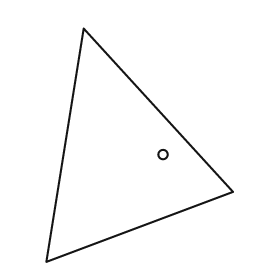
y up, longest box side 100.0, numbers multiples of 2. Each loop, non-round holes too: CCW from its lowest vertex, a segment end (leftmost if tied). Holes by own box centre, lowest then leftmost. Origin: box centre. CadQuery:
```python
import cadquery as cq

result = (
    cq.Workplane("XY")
    .moveTo(-40.0, -50.0)
    .lineTo(40.0, -20.0)
    .lineTo(-24.0, 50.0)
    .close()
    .moveTo(10.0, -4.0)
    .circle(2.0)
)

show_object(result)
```